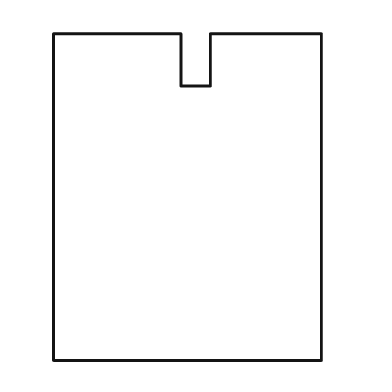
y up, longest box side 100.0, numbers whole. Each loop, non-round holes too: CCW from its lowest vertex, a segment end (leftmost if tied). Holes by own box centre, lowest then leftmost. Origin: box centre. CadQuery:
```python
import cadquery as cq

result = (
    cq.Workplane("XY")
    .moveTo(-41.0, -50.0)
    .lineTo(41.0, -50.0)
    .lineTo(41.0, 50.0)
    .lineTo(7.0, 50.0)
    .lineTo(7.0, 34.0)
    .lineTo(-2.0, 34.0)
    .lineTo(-2.0, 50.0)
    .lineTo(-41.0, 50.0)
    .close()
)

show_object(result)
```